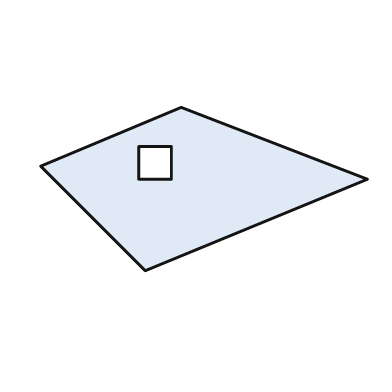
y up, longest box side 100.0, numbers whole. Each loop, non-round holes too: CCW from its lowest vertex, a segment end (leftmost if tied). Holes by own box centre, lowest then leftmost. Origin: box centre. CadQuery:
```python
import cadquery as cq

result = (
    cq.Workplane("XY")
    .moveTo(-18.0, -25.0)
    .lineTo(50.0, 3.0)
    .lineTo(-7.0, 25.0)
    .lineTo(-50.0, 7.0)
    .close()
    .moveTo(-20.0, 3.0)
    .lineTo(-10.0, 3.0)
    .lineTo(-10.0, 13.0)
    .lineTo(-20.0, 13.0)
    .close()
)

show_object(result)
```